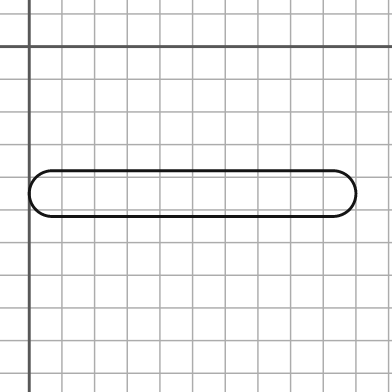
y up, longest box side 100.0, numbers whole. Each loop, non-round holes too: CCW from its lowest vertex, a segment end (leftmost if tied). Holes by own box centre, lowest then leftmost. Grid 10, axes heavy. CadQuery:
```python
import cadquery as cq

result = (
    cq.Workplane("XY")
    .moveTo(7.0, -52.0)
    .lineTo(93.0, -52.0)
    .threePointArc((100.0, -45.0), (93.0, -38.0))
    .lineTo(7.0, -38.0)
    .threePointArc((0.0, -45.0), (7.0, -52.0))
    .close()
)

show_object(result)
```